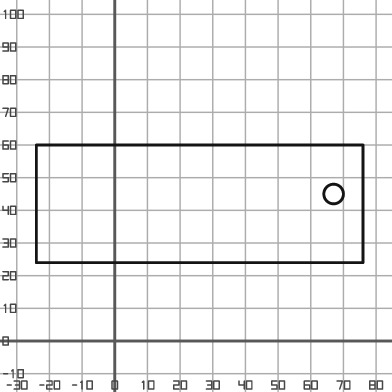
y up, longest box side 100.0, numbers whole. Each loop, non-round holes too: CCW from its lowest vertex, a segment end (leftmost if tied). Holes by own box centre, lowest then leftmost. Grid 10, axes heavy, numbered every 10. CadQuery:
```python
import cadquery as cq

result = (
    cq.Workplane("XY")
    .moveTo(-24.0, 24.0)
    .lineTo(76.0, 24.0)
    .lineTo(76.0, 60.0)
    .lineTo(-24.0, 60.0)
    .close()
    .moveTo(67.0, 45.0)
    .circle(3.0)
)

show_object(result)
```